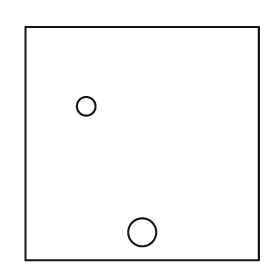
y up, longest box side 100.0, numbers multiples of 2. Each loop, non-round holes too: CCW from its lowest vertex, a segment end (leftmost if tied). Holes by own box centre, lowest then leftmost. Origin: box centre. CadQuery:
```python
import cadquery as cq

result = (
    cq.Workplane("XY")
    .moveTo(-50.0, -50.0)
    .lineTo(50.0, -50.0)
    .lineTo(50.0, 50.0)
    .lineTo(-50.0, 50.0)
    .close()
    .moveTo(0.0, -38.0)
    .circle(6.0)
    .moveTo(-24.0, 16.0)
    .circle(4.0)
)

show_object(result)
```